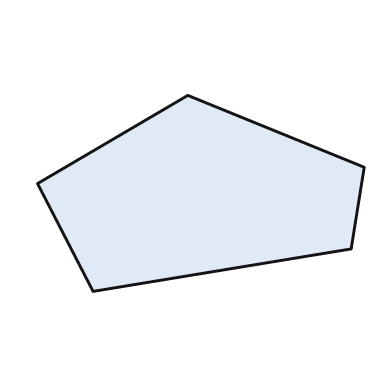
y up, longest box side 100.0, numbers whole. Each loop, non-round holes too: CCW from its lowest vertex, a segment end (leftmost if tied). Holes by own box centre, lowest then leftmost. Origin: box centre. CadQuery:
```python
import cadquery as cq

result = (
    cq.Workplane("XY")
    .moveTo(-33.0, -30.0)
    .lineTo(46.0, -17.0)
    .lineTo(50.0, 8.0)
    .lineTo(-4.0, 30.0)
    .lineTo(-50.0, 3.0)
    .close()
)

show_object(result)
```